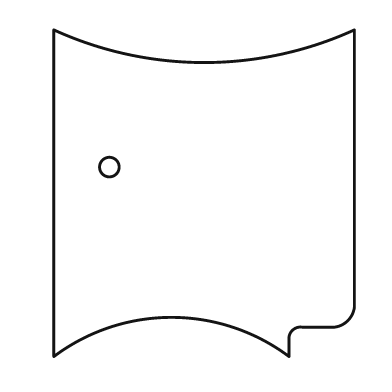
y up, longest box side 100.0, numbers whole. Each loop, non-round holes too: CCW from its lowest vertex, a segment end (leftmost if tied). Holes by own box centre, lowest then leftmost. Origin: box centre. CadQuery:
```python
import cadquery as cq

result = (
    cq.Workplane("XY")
    .moveTo(-46.0, -50.0)
    .threePointArc((-10.0, -38.0), (26.0, -50.0))
    .lineTo(26.0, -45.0)
    .threePointArc((27.0, -42.0), (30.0, -41.0))
    .lineTo(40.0, -41.0)
    .threePointArc((44.0, -39.0), (46.0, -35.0))
    .lineTo(46.0, 50.0)
    .threePointArc((0.0, 40.0), (-46.0, 50.0))
    .close()
    .moveTo(-29.0, 8.0)
    .circle(3.0)
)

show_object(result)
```